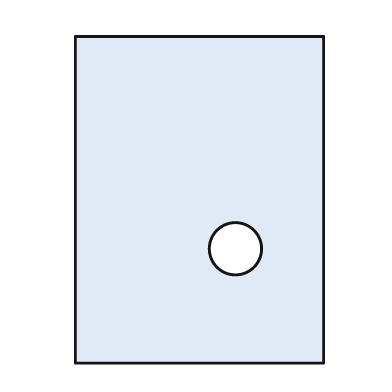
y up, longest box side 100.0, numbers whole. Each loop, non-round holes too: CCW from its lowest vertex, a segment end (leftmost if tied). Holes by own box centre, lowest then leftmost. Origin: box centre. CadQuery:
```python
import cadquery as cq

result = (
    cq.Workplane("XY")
    .moveTo(-38.0, -50.0)
    .lineTo(38.0, -50.0)
    .lineTo(38.0, 50.0)
    .lineTo(-38.0, 50.0)
    .close()
    .moveTo(11.0, -15.0)
    .circle(8.0)
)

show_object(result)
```